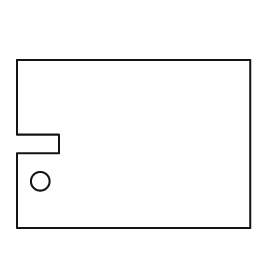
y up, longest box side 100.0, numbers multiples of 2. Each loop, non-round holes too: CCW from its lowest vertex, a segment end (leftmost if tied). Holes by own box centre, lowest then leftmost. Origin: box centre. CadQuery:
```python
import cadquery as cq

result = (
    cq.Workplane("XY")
    .moveTo(-50.0, -36.0)
    .lineTo(50.0, -36.0)
    .lineTo(50.0, 36.0)
    .lineTo(-50.0, 36.0)
    .lineTo(-50.0, 4.0)
    .lineTo(-32.0, 4.0)
    .lineTo(-32.0, -4.0)
    .lineTo(-50.0, -4.0)
    .close()
    .moveTo(-40.0, -16.0)
    .circle(4.0)
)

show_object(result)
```